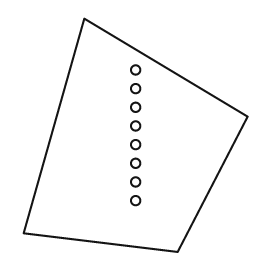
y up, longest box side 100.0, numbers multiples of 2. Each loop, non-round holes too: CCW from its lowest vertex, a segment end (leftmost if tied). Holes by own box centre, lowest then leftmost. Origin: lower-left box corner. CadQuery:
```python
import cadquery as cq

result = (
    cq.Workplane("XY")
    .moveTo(66.0, 0.0)
    .lineTo(96.0, 58.0)
    .lineTo(26.0, 100.0)
    .lineTo(0.0, 8.0)
    .close()
    .moveTo(48.0, 22.0)
    .circle(2.0)
    .moveTo(48.0, 30.0)
    .circle(2.0)
    .moveTo(48.0, 38.0)
    .circle(2.0)
    .moveTo(48.0, 46.0)
    .circle(2.0)
    .moveTo(48.0, 54.0)
    .circle(2.0)
    .moveTo(48.0, 62.0)
    .circle(2.0)
    .moveTo(48.0, 70.0)
    .circle(2.0)
    .moveTo(48.0, 78.0)
    .circle(2.0)
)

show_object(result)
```